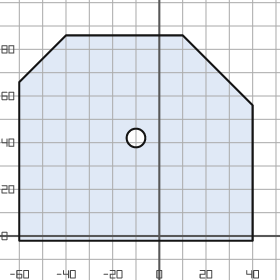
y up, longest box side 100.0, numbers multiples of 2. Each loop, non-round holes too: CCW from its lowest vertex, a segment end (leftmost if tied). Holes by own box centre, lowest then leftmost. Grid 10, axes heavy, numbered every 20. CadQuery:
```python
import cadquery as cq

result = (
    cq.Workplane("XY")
    .moveTo(-60.0, -2.0)
    .lineTo(40.0, -2.0)
    .lineTo(40.0, 56.0)
    .lineTo(10.0, 86.0)
    .lineTo(-40.0, 86.0)
    .lineTo(-60.0, 66.0)
    .close()
    .moveTo(-10.0, 42.0)
    .circle(4.0)
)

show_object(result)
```